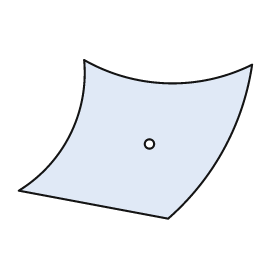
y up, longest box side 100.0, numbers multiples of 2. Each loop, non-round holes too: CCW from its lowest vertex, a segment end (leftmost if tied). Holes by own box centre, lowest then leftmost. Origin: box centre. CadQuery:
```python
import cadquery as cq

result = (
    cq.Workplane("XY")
    .moveTo(14.0, -34.0)
    .threePointArc((38.0, -4.0), (50.0, 32.0))
    .threePointArc((14.0, 24.0), (-22.0, 34.0))
    .threePointArc((-28.0, 2.0), (-50.0, -22.0))
    .close()
    .moveTo(6.0, -2.0)
    .circle(2.0)
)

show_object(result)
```